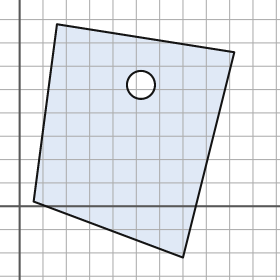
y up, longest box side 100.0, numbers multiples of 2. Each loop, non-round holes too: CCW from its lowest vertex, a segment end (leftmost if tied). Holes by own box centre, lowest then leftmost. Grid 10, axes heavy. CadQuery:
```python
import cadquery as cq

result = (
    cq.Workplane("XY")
    .moveTo(70.0, -22.0)
    .lineTo(92.0, 66.0)
    .lineTo(16.0, 78.0)
    .lineTo(6.0, 2.0)
    .close()
    .moveTo(52.0, 52.0)
    .circle(6.0)
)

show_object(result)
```